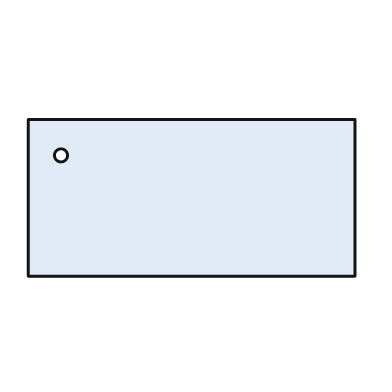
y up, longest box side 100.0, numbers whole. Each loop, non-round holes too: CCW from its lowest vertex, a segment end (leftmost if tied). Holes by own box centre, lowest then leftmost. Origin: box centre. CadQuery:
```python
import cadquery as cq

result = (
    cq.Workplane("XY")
    .moveTo(-50.0, -24.0)
    .lineTo(50.0, -24.0)
    .lineTo(50.0, 24.0)
    .lineTo(-50.0, 24.0)
    .close()
    .moveTo(-40.0, 13.0)
    .circle(2.0)
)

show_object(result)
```